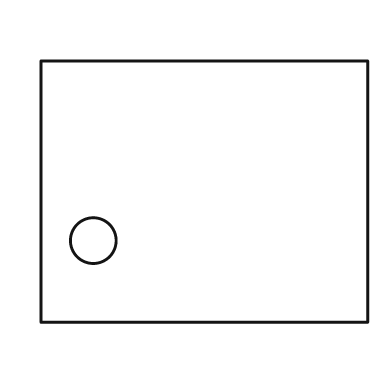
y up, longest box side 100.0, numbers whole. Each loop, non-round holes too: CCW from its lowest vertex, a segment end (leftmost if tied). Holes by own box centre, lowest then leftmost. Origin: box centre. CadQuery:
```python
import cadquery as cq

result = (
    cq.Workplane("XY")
    .moveTo(-50.0, -40.0)
    .lineTo(50.0, -40.0)
    .lineTo(50.0, 40.0)
    .lineTo(-50.0, 40.0)
    .close()
    .moveTo(-34.0, -15.0)
    .circle(7.0)
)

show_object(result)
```